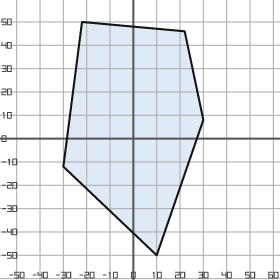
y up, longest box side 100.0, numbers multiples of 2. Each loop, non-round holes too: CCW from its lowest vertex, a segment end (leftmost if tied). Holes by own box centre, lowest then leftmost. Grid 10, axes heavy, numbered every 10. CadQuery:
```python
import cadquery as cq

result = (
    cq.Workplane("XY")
    .moveTo(10.0, -50.0)
    .lineTo(30.0, 8.0)
    .lineTo(22.0, 46.0)
    .lineTo(-22.0, 50.0)
    .lineTo(-30.0, -12.0)
    .close()
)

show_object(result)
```